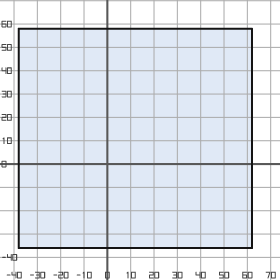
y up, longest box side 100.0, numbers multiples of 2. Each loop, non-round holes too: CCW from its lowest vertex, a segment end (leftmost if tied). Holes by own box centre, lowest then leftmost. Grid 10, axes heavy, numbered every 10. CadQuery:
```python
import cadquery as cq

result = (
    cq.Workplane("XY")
    .moveTo(-38.0, -36.0)
    .lineTo(62.0, -36.0)
    .lineTo(62.0, 58.0)
    .lineTo(-38.0, 58.0)
    .close()
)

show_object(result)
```